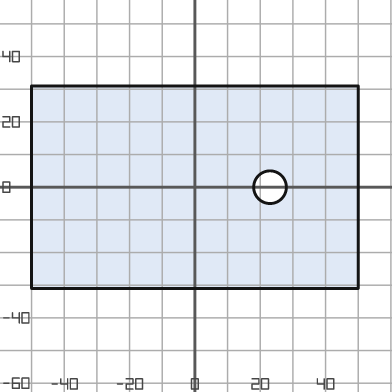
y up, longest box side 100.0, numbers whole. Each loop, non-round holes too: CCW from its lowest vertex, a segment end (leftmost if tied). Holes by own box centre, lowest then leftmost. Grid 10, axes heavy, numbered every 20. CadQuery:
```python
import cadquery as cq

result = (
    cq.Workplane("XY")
    .moveTo(-50.0, -31.0)
    .lineTo(50.0, -31.0)
    .lineTo(50.0, 31.0)
    .lineTo(-50.0, 31.0)
    .close()
    .moveTo(23.0, 0.0)
    .circle(5.0)
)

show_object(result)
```